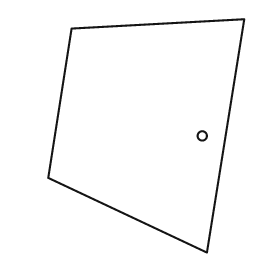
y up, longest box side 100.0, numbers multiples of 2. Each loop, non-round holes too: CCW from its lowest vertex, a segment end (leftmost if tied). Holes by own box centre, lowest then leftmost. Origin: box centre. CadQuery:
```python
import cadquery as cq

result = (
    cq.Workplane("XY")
    .moveTo(26.0, -50.0)
    .lineTo(42.0, 50.0)
    .lineTo(-32.0, 46.0)
    .lineTo(-42.0, -18.0)
    .close()
    .moveTo(24.0, 0.0)
    .circle(2.0)
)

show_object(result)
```